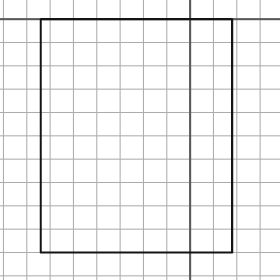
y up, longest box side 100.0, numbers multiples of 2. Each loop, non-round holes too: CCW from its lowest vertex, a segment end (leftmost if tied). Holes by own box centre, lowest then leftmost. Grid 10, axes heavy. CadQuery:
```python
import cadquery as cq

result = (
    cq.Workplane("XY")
    .moveTo(-64.0, -100.0)
    .lineTo(18.0, -100.0)
    .lineTo(18.0, 0.0)
    .lineTo(-64.0, 0.0)
    .close()
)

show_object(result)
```